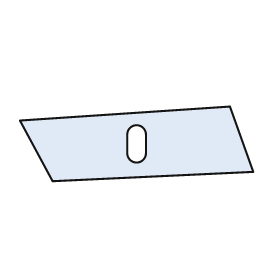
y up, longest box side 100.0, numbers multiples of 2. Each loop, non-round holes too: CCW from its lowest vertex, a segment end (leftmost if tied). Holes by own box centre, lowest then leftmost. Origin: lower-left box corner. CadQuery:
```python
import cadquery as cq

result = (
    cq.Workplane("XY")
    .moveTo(14.0, 0.0)
    .lineTo(100.0, 4.0)
    .lineTo(90.0, 32.0)
    .lineTo(0.0, 26.0)
    .close()
    .moveTo(46.0, 12.0)
    .threePointArc((50.0, 8.0), (54.0, 12.0))
    .lineTo(54.0, 20.0)
    .threePointArc((50.0, 24.0), (46.0, 20.0))
    .close()
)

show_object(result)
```